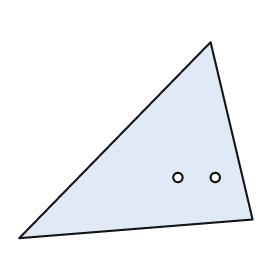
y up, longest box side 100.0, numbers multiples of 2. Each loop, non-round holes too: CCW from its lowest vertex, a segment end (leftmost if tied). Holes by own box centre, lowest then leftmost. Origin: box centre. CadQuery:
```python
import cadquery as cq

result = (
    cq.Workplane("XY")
    .moveTo(-50.0, -42.0)
    .lineTo(50.0, -34.0)
    .lineTo(32.0, 42.0)
    .close()
    .moveTo(18.0, -16.0)
    .circle(2.0)
    .moveTo(34.0, -16.0)
    .circle(2.0)
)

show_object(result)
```